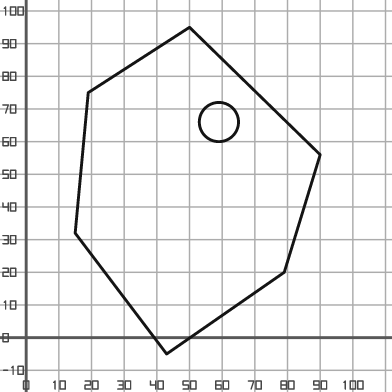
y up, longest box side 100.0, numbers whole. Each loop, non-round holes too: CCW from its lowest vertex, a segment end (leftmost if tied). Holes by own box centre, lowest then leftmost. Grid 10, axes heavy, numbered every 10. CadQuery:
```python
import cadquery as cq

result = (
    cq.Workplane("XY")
    .moveTo(43.0, -5.0)
    .lineTo(79.0, 20.0)
    .lineTo(90.0, 56.0)
    .lineTo(50.0, 95.0)
    .lineTo(19.0, 75.0)
    .lineTo(15.0, 32.0)
    .close()
    .moveTo(59.0, 66.0)
    .circle(6.0)
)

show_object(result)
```